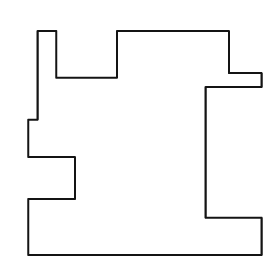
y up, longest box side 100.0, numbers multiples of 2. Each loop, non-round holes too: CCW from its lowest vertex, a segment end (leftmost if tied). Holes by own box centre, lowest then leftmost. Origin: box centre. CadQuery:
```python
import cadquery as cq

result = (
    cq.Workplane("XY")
    .moveTo(-50.0, -48.0)
    .lineTo(50.0, -48.0)
    .lineTo(50.0, -32.0)
    .lineTo(26.0, -32.0)
    .lineTo(26.0, 24.0)
    .lineTo(50.0, 24.0)
    .lineTo(50.0, 30.0)
    .lineTo(36.0, 30.0)
    .lineTo(36.0, 48.0)
    .lineTo(-12.0, 48.0)
    .lineTo(-12.0, 28.0)
    .lineTo(-38.0, 28.0)
    .lineTo(-38.0, 48.0)
    .lineTo(-46.0, 48.0)
    .lineTo(-46.0, 10.0)
    .lineTo(-50.0, 10.0)
    .lineTo(-50.0, -6.0)
    .lineTo(-30.0, -6.0)
    .lineTo(-30.0, -24.0)
    .lineTo(-50.0, -24.0)
    .close()
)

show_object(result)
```